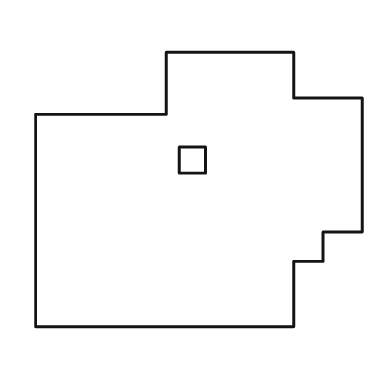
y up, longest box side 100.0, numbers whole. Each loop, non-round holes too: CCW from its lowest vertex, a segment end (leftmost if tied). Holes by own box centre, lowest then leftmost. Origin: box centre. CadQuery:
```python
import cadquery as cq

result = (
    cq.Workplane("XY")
    .moveTo(-50.0, -42.0)
    .lineTo(29.0, -42.0)
    .lineTo(29.0, -22.0)
    .lineTo(38.0, -22.0)
    .lineTo(38.0, -13.0)
    .lineTo(50.0, -13.0)
    .lineTo(50.0, 28.0)
    .lineTo(29.0, 28.0)
    .lineTo(29.0, 42.0)
    .lineTo(-10.0, 42.0)
    .lineTo(-10.0, 23.0)
    .lineTo(-50.0, 23.0)
    .close()
    .moveTo(-6.0, 5.0)
    .lineTo(2.0, 5.0)
    .lineTo(2.0, 13.0)
    .lineTo(-6.0, 13.0)
    .close()
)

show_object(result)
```